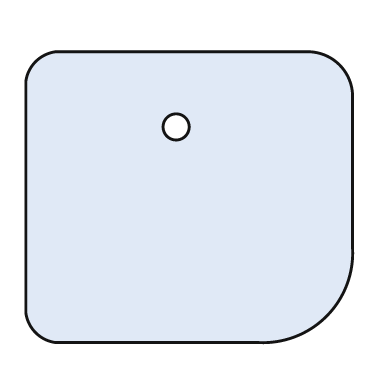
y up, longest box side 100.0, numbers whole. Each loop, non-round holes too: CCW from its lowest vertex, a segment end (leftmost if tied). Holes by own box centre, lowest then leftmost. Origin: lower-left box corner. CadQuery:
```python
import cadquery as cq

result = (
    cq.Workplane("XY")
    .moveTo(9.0, 0.0)
    .lineTo(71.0, 0.0)
    .threePointArc((92.0, 8.0), (100.0, 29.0))
    .lineTo(100.0, 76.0)
    .threePointArc((96.0, 85.0), (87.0, 89.0))
    .lineTo(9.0, 89.0)
    .threePointArc((3.0, 86.0), (0.0, 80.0))
    .lineTo(0.0, 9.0)
    .threePointArc((3.0, 3.0), (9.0, 0.0))
    .close()
    .moveTo(46.0, 66.0)
    .circle(4.0)
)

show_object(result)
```